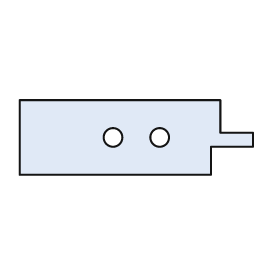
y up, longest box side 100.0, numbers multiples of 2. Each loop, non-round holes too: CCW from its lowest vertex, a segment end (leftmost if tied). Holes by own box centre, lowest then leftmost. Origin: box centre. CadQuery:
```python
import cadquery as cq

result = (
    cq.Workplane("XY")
    .moveTo(-50.0, -16.0)
    .lineTo(32.0, -16.0)
    .lineTo(32.0, -4.0)
    .lineTo(50.0, -4.0)
    .lineTo(50.0, 2.0)
    .lineTo(36.0, 2.0)
    .lineTo(36.0, 16.0)
    .lineTo(-50.0, 16.0)
    .close()
    .moveTo(-10.0, 0.0)
    .circle(4.0)
    .moveTo(10.0, 0.0)
    .circle(4.0)
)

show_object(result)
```